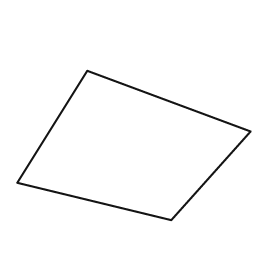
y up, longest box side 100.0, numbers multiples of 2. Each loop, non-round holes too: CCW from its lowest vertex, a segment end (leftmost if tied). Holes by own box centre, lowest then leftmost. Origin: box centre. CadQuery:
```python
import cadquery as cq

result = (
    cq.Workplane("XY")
    .moveTo(16.0, -32.0)
    .lineTo(50.0, 6.0)
    .lineTo(-20.0, 32.0)
    .lineTo(-50.0, -16.0)
    .close()
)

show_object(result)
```